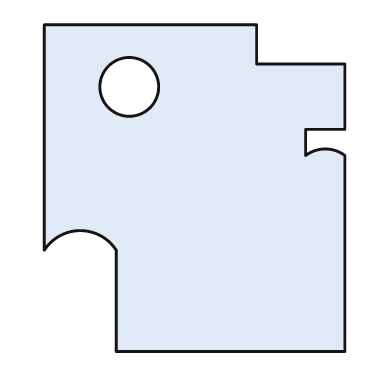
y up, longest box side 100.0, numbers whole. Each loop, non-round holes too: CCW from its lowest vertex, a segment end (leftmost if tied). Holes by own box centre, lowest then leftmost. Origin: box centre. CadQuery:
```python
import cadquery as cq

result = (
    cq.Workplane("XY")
    .moveTo(-24.0, -50.0)
    .lineTo(46.0, -50.0)
    .lineTo(46.0, 10.0)
    .threePointArc((40.0, 12.0), (34.0, 10.0))
    .lineTo(34.0, 18.0)
    .lineTo(46.0, 18.0)
    .lineTo(46.0, 38.0)
    .lineTo(19.0, 38.0)
    .lineTo(19.0, 50.0)
    .lineTo(-46.0, 50.0)
    .lineTo(-46.0, -19.0)
    .threePointArc((-35.0, -13.0), (-24.0, -19.0))
    .close()
    .moveTo(-20.0, 31.0)
    .circle(9.0)
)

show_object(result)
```